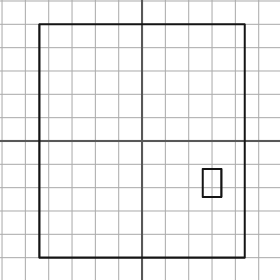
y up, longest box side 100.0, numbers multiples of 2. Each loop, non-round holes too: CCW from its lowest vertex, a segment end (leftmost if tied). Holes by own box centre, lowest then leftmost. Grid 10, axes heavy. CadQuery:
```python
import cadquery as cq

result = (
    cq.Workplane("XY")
    .moveTo(-44.0, -50.0)
    .lineTo(44.0, -50.0)
    .lineTo(44.0, 50.0)
    .lineTo(-44.0, 50.0)
    .close()
    .moveTo(26.0, -24.0)
    .lineTo(34.0, -24.0)
    .lineTo(34.0, -12.0)
    .lineTo(26.0, -12.0)
    .close()
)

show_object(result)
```